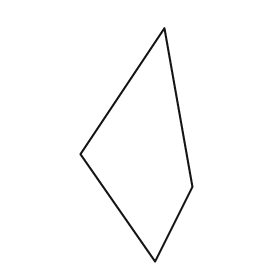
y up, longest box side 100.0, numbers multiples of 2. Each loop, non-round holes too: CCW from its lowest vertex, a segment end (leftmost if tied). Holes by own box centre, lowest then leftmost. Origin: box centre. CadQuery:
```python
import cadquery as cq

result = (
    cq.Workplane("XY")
    .moveTo(8.0, -50.0)
    .lineTo(24.0, -18.0)
    .lineTo(12.0, 50.0)
    .lineTo(-24.0, -4.0)
    .close()
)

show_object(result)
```